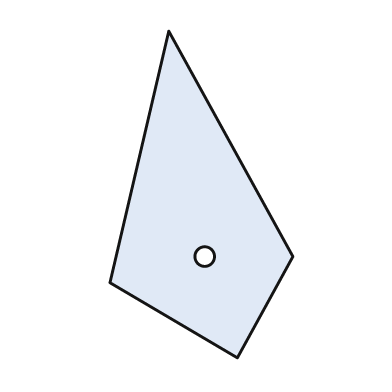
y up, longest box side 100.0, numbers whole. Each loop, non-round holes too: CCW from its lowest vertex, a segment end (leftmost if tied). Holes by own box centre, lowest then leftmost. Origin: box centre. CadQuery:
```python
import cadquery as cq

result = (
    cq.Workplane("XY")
    .moveTo(11.0, -50.0)
    .lineTo(28.0, -19.0)
    .lineTo(-10.0, 50.0)
    .lineTo(-28.0, -27.0)
    .close()
    .moveTo(1.0, -19.0)
    .circle(3.0)
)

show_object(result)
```